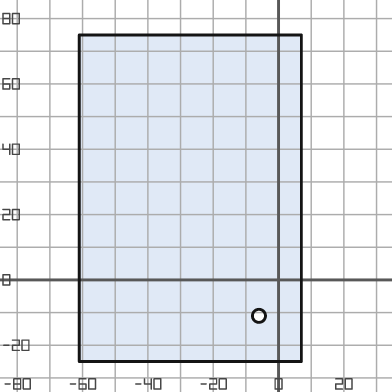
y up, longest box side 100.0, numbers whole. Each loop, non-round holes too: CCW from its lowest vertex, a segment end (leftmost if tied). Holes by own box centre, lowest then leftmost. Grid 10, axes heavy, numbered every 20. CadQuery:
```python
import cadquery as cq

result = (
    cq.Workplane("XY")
    .moveTo(-61.0, -25.0)
    .lineTo(7.0, -25.0)
    .lineTo(7.0, 75.0)
    .lineTo(-61.0, 75.0)
    .close()
    .moveTo(-6.0, -11.0)
    .circle(2.0)
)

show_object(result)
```